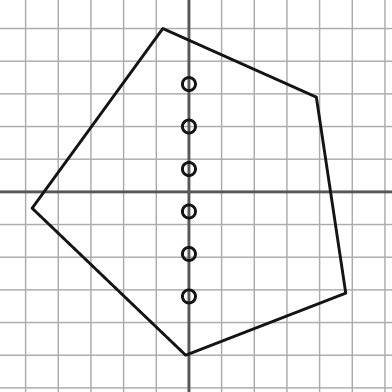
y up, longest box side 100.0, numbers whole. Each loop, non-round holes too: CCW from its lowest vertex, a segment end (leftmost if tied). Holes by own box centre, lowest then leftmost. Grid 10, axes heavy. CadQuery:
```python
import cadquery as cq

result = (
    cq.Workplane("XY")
    .moveTo(-1.0, -50.0)
    .lineTo(48.0, -31.0)
    .lineTo(39.0, 29.0)
    .lineTo(-8.0, 50.0)
    .lineTo(-48.0, -5.0)
    .close()
    .moveTo(0.0, -32.0)
    .circle(2.0)
    .moveTo(0.0, -19.0)
    .circle(2.0)
    .moveTo(0.0, -6.0)
    .circle(2.0)
    .moveTo(0.0, 7.0)
    .circle(2.0)
    .moveTo(0.0, 20.0)
    .circle(2.0)
    .moveTo(0.0, 33.0)
    .circle(2.0)
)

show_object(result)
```